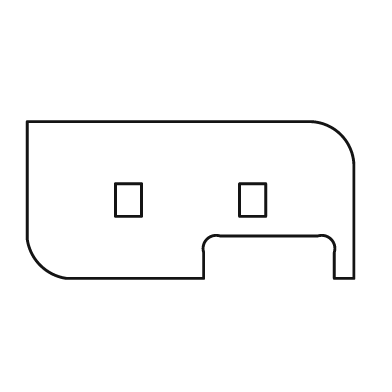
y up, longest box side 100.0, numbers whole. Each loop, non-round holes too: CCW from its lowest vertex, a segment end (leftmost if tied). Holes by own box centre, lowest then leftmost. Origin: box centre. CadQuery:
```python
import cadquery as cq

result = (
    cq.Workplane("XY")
    .moveTo(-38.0, -24.0)
    .lineTo(4.0, -24.0)
    .lineTo(4.0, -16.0)
    .threePointArc((5.0, -12.0), (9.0, -11.0))
    .lineTo(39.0, -11.0)
    .threePointArc((43.0, -12.0), (44.0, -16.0))
    .lineTo(44.0, -24.0)
    .lineTo(50.0, -24.0)
    .lineTo(50.0, 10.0)
    .threePointArc((46.0, 20.0), (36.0, 24.0))
    .lineTo(-50.0, 24.0)
    .lineTo(-50.0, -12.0)
    .threePointArc((-46.0, -20.0), (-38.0, -24.0))
    .close()
    .moveTo(-23.0, -5.0)
    .lineTo(-15.0, -5.0)
    .lineTo(-15.0, 5.0)
    .lineTo(-23.0, 5.0)
    .close()
    .moveTo(15.0, -5.0)
    .lineTo(23.0, -5.0)
    .lineTo(23.0, 5.0)
    .lineTo(15.0, 5.0)
    .close()
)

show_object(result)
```